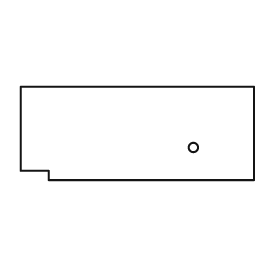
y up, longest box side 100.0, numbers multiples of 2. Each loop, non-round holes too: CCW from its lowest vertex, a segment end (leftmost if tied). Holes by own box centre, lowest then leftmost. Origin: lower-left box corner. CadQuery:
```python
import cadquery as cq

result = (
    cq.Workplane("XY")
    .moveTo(12.0, 0.0)
    .lineTo(100.0, 0.0)
    .lineTo(100.0, 40.0)
    .lineTo(0.0, 40.0)
    .lineTo(0.0, 4.0)
    .lineTo(12.0, 4.0)
    .close()
    .moveTo(74.0, 14.0)
    .circle(2.0)
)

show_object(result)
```